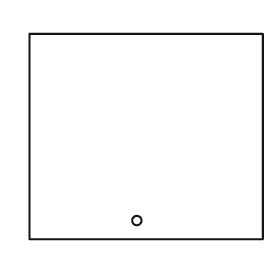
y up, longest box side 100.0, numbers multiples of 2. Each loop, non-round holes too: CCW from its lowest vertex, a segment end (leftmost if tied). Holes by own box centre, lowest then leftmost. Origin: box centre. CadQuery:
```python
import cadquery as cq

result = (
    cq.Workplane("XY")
    .moveTo(-50.0, -44.0)
    .lineTo(50.0, -44.0)
    .lineTo(50.0, 44.0)
    .lineTo(-50.0, 44.0)
    .close()
    .moveTo(-4.0, -36.0)
    .circle(2.0)
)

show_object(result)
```